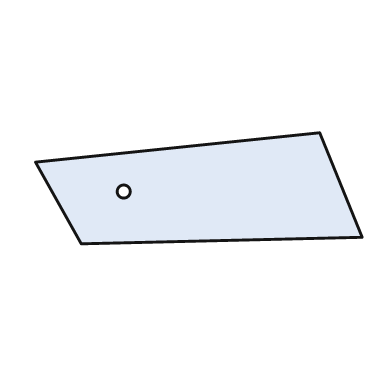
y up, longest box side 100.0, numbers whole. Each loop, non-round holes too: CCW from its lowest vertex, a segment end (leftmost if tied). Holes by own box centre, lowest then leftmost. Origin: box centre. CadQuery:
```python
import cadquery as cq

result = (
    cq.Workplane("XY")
    .moveTo(-36.0, -17.0)
    .lineTo(50.0, -15.0)
    .lineTo(37.0, 17.0)
    .lineTo(-50.0, 8.0)
    .close()
    .moveTo(-23.0, -1.0)
    .circle(2.0)
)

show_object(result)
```